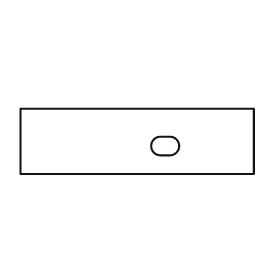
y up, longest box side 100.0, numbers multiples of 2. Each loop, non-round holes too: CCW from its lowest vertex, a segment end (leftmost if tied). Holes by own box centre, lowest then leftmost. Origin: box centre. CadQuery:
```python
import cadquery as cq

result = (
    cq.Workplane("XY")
    .moveTo(-50.0, -14.0)
    .lineTo(50.0, -14.0)
    .lineTo(50.0, 14.0)
    .lineTo(-50.0, 14.0)
    .close()
    .moveTo(10.0, -6.0)
    .lineTo(14.0, -6.0)
    .threePointArc((18.0, -2.0), (14.0, 2.0))
    .lineTo(10.0, 2.0)
    .threePointArc((6.0, -2.0), (10.0, -6.0))
    .close()
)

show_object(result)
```